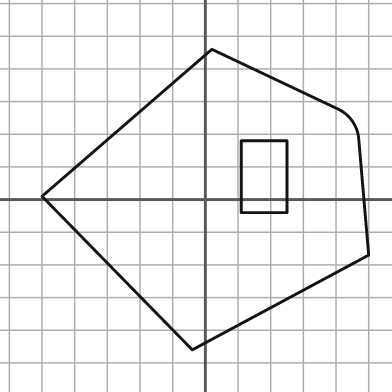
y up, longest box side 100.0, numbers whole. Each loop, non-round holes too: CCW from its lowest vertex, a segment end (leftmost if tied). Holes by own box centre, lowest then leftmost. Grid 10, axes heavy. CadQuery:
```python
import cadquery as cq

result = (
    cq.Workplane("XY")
    .moveTo(-4.0, -46.0)
    .lineTo(50.0, -17.0)
    .lineTo(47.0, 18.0)
    .threePointArc((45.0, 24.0), (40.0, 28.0))
    .lineTo(2.0, 46.0)
    .lineTo(-50.0, 1.0)
    .close()
    .moveTo(11.0, -4.0)
    .lineTo(25.0, -4.0)
    .lineTo(25.0, 18.0)
    .lineTo(11.0, 18.0)
    .close()
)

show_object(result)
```